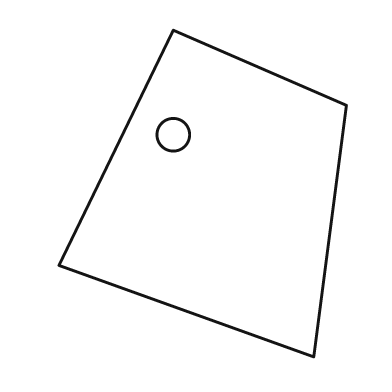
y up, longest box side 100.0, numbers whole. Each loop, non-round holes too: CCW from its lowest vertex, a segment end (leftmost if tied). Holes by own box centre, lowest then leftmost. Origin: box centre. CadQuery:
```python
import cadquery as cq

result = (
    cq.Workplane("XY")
    .moveTo(34.0, -50.0)
    .lineTo(44.0, 27.0)
    .lineTo(-9.0, 50.0)
    .lineTo(-44.0, -22.0)
    .close()
    .moveTo(-9.0, 18.0)
    .circle(5.0)
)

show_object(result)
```